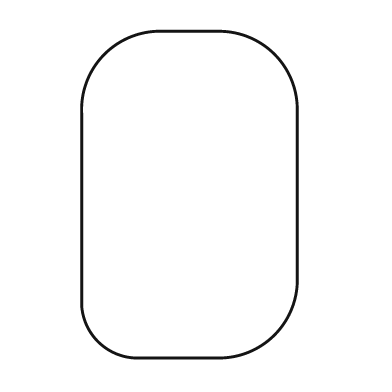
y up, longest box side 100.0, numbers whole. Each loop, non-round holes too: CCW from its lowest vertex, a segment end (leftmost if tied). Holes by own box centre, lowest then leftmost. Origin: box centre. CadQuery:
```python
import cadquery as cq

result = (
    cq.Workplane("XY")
    .moveTo(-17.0, -50.0)
    .lineTo(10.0, -50.0)
    .threePointArc((26.0, -43.0), (33.0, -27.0))
    .lineTo(33.0, 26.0)
    .threePointArc((26.0, 43.0), (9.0, 50.0))
    .lineTo(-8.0, 50.0)
    .threePointArc((-26.0, 43.0), (-33.0, 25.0))
    .lineTo(-33.0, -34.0)
    .threePointArc((-28.0, -45.0), (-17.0, -50.0))
    .close()
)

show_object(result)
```